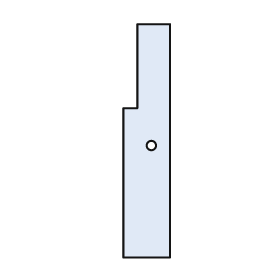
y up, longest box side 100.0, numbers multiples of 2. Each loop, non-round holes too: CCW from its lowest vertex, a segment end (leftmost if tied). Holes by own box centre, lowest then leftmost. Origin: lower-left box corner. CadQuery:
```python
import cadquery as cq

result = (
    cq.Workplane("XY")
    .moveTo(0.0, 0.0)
    .lineTo(20.0, 0.0)
    .lineTo(20.0, 100.0)
    .lineTo(6.0, 100.0)
    .lineTo(6.0, 64.0)
    .lineTo(0.0, 64.0)
    .close()
    .moveTo(12.0, 48.0)
    .circle(2.0)
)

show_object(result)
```